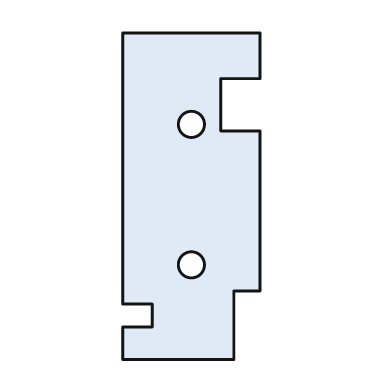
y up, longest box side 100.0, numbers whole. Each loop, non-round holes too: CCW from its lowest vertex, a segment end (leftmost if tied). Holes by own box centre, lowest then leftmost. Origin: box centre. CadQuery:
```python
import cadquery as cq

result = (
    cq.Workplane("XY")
    .moveTo(-21.0, -50.0)
    .lineTo(13.0, -50.0)
    .lineTo(13.0, -29.0)
    .lineTo(21.0, -29.0)
    .lineTo(21.0, 20.0)
    .lineTo(9.0, 20.0)
    .lineTo(9.0, 36.0)
    .lineTo(21.0, 36.0)
    .lineTo(21.0, 50.0)
    .lineTo(-21.0, 50.0)
    .lineTo(-21.0, -33.0)
    .lineTo(-12.0, -33.0)
    .lineTo(-12.0, -40.0)
    .lineTo(-21.0, -40.0)
    .close()
    .moveTo(0.0, -21.0)
    .circle(4.0)
    .moveTo(0.0, 22.0)
    .circle(4.0)
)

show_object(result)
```